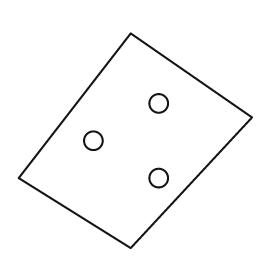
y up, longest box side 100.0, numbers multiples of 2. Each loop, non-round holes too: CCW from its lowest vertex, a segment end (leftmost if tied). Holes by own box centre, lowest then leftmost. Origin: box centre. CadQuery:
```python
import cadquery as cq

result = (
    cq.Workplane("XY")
    .moveTo(-2.0, -46.0)
    .lineTo(50.0, 10.0)
    .lineTo(-2.0, 46.0)
    .lineTo(-50.0, -16.0)
    .close()
    .moveTo(10.0, -16.0)
    .circle(4.0)
    .moveTo(-18.0, 0.0)
    .circle(4.0)
    .moveTo(10.0, 16.0)
    .circle(4.0)
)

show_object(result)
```